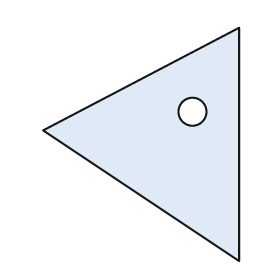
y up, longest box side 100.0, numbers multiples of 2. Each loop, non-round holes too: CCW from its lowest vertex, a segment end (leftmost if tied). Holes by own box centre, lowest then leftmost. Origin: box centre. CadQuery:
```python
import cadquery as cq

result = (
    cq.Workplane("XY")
    .moveTo(42.0, -50.0)
    .lineTo(42.0, 50.0)
    .lineTo(-42.0, 6.0)
    .close()
    .moveTo(22.0, 14.0)
    .circle(6.0)
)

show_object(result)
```